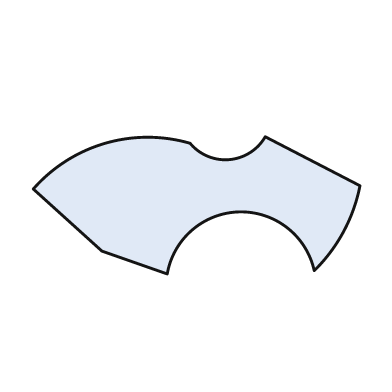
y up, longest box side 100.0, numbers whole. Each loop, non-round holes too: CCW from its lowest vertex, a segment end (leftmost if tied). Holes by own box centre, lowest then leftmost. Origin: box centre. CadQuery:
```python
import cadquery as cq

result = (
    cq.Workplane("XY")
    .moveTo(-9.0, -21.0)
    .threePointArc((13.0, -2.0), (36.0, -20.0))
    .threePointArc((45.0, -8.0), (50.0, 6.0))
    .lineTo(21.0, 21.0)
    .threePointArc((10.0, 14.0), (-2.0, 19.0))
    .threePointArc((-28.0, 19.0), (-50.0, 5.0))
    .lineTo(-29.0, -14.0)
    .close()
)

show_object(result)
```